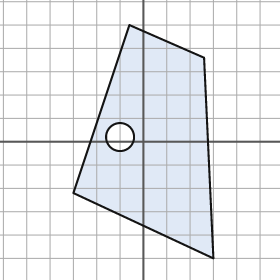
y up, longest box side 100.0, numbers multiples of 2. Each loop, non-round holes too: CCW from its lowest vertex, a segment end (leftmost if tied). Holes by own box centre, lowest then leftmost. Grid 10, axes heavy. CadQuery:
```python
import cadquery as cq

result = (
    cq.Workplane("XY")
    .moveTo(30.0, -50.0)
    .lineTo(26.0, 36.0)
    .lineTo(-6.0, 50.0)
    .lineTo(-30.0, -22.0)
    .close()
    .moveTo(-10.0, 2.0)
    .circle(6.0)
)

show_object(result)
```